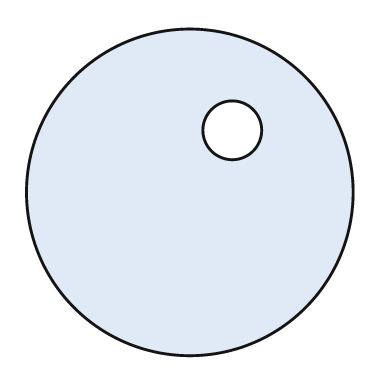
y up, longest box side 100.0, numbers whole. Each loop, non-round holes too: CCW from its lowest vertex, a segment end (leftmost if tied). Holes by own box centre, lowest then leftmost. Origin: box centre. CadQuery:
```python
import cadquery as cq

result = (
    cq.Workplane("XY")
    .moveTo(0.0, 0.0)
    .circle(50.0)
    .moveTo(13.0, 19.0)
    .circle(9.0)
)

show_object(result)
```